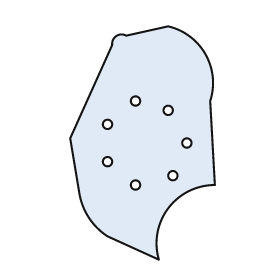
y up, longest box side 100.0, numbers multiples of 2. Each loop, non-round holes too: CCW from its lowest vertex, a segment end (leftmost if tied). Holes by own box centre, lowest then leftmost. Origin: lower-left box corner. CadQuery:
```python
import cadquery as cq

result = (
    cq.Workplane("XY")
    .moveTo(38.0, 0.0)
    .threePointArc((42.0, 22.0), (62.0, 32.0))
    .lineTo(60.0, 68.0)
    .threePointArc((58.0, 88.0), (42.0, 100.0))
    .lineTo(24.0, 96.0)
    .threePointArc((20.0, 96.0), (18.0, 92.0))
    .lineTo(0.0, 52.0)
    .lineTo(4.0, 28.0)
    .threePointArc((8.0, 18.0), (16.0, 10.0))
    .close()
    .moveTo(28.0, 32.0)
    .circle(2.0)
    .moveTo(44.0, 36.0)
    .circle(2.0)
    .moveTo(16.0, 42.0)
    .circle(2.0)
    .moveTo(50.0, 50.0)
    .circle(2.0)
    .moveTo(16.0, 58.0)
    .circle(2.0)
    .moveTo(42.0, 64.0)
    .circle(2.0)
    .moveTo(28.0, 68.0)
    .circle(2.0)
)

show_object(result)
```